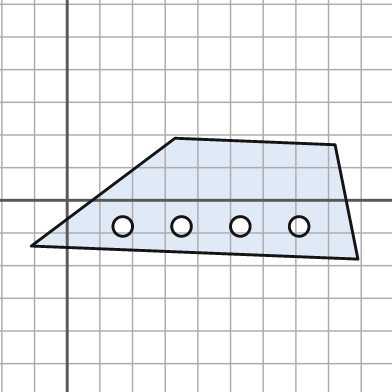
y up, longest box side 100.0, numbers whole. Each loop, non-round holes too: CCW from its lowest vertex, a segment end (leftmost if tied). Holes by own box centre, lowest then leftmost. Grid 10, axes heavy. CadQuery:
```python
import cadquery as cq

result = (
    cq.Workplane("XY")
    .moveTo(89.0, -18.0)
    .lineTo(82.0, 17.0)
    .lineTo(33.0, 19.0)
    .lineTo(-11.0, -14.0)
    .close()
    .moveTo(17.0, -8.0)
    .circle(3.0)
    .moveTo(35.0, -8.0)
    .circle(3.0)
    .moveTo(53.0, -8.0)
    .circle(3.0)
    .moveTo(71.0, -8.0)
    .circle(3.0)
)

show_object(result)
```